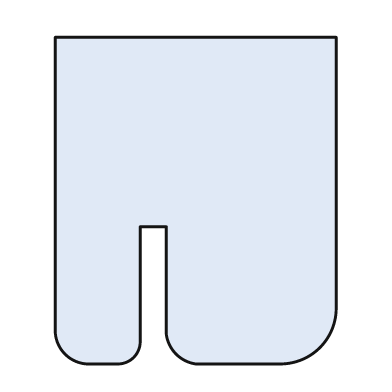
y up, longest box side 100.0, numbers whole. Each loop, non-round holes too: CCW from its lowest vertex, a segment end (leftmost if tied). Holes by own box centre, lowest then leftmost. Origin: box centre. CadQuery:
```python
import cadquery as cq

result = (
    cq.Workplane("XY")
    .moveTo(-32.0, -50.0)
    .lineTo(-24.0, -50.0)
    .threePointArc((-19.0, -48.0), (-17.0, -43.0))
    .lineTo(-17.0, -8.0)
    .lineTo(-9.0, -8.0)
    .lineTo(-9.0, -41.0)
    .threePointArc((-6.0, -47.0), (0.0, -50.0))
    .lineTo(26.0, -50.0)
    .threePointArc((38.0, -45.0), (43.0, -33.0))
    .lineTo(43.0, 50.0)
    .lineTo(-43.0, 50.0)
    .lineTo(-43.0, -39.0)
    .threePointArc((-40.0, -47.0), (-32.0, -50.0))
    .close()
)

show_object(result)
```